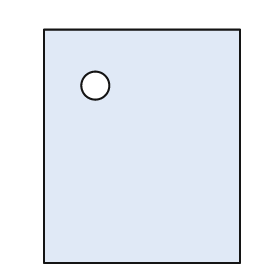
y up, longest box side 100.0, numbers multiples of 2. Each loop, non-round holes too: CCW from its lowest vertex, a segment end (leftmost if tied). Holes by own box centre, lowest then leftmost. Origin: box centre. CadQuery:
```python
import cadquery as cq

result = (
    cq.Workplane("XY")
    .moveTo(-42.0, -50.0)
    .lineTo(42.0, -50.0)
    .lineTo(42.0, 50.0)
    .lineTo(-42.0, 50.0)
    .close()
    .moveTo(-20.0, 26.0)
    .circle(6.0)
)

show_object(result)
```